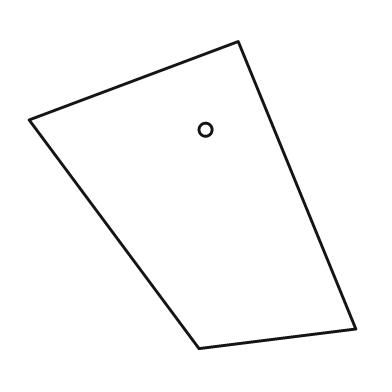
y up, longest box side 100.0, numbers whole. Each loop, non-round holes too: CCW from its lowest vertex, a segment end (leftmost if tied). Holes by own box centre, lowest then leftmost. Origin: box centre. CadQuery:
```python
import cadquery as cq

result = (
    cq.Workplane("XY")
    .moveTo(2.0, -47.0)
    .lineTo(50.0, -41.0)
    .lineTo(14.0, 47.0)
    .lineTo(-50.0, 23.0)
    .close()
    .moveTo(4.0, 20.0)
    .circle(2.0)
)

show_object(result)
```